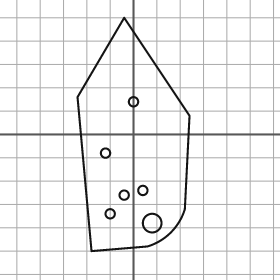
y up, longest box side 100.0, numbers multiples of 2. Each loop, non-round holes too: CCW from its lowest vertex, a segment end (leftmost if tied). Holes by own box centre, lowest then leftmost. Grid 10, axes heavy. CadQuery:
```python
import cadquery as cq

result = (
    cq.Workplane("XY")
    .moveTo(-18.0, -50.0)
    .lineTo(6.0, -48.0)
    .threePointArc((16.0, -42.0), (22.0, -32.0))
    .lineTo(24.0, 8.0)
    .lineTo(-4.0, 50.0)
    .lineTo(-24.0, 16.0)
    .close()
    .moveTo(8.0, -38.0)
    .circle(4.0)
    .moveTo(-10.0, -34.0)
    .circle(2.0)
    .moveTo(-4.0, -26.0)
    .circle(2.0)
    .moveTo(4.0, -24.0)
    .circle(2.0)
    .moveTo(-12.0, -8.0)
    .circle(2.0)
    .moveTo(0.0, 14.0)
    .circle(2.0)
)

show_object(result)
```